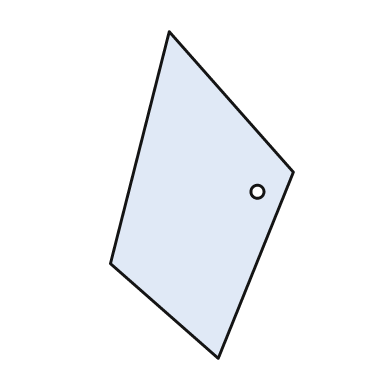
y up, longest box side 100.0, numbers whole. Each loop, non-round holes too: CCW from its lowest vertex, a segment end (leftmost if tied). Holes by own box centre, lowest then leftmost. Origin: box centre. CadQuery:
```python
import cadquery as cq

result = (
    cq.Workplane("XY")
    .moveTo(5.0, -50.0)
    .lineTo(28.0, 7.0)
    .lineTo(-10.0, 50.0)
    .lineTo(-28.0, -21.0)
    .close()
    .moveTo(17.0, 1.0)
    .circle(2.0)
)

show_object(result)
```